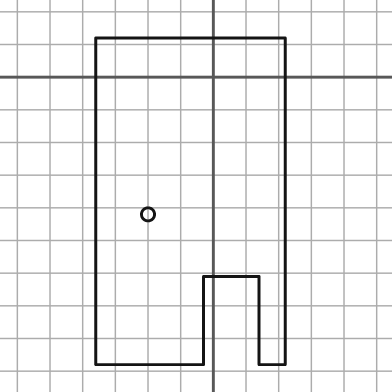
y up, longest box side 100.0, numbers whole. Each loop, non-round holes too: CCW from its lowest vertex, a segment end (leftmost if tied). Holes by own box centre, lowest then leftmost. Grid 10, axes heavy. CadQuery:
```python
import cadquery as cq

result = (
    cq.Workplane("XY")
    .moveTo(-36.0, -88.0)
    .lineTo(-3.0, -88.0)
    .lineTo(-3.0, -61.0)
    .lineTo(14.0, -61.0)
    .lineTo(14.0, -88.0)
    .lineTo(22.0, -88.0)
    .lineTo(22.0, 12.0)
    .lineTo(-36.0, 12.0)
    .close()
    .moveTo(-20.0, -42.0)
    .circle(2.0)
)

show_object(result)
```